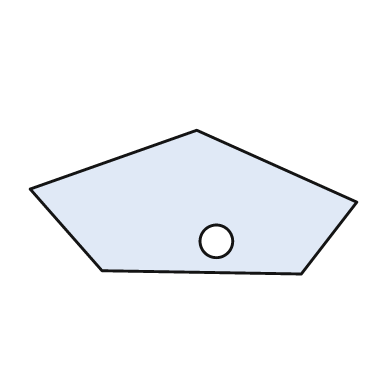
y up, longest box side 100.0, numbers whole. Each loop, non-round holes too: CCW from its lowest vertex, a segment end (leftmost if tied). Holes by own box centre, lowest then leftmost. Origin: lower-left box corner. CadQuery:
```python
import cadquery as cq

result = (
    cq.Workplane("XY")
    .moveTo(83.0, 0.0)
    .lineTo(100.0, 22.0)
    .lineTo(51.0, 44.0)
    .lineTo(0.0, 26.0)
    .lineTo(22.0, 1.0)
    .close()
    .moveTo(57.0, 10.0)
    .circle(5.0)
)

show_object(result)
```